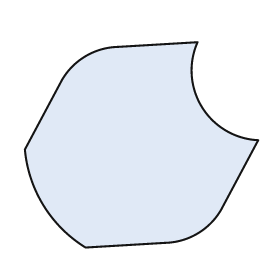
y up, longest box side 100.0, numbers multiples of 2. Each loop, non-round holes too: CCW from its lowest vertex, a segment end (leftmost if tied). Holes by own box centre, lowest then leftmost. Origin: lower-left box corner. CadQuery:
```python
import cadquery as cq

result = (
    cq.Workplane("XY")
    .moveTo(26.0, 0.0)
    .lineTo(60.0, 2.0)
    .threePointArc((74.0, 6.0), (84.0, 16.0))
    .lineTo(100.0, 46.0)
    .threePointArc((76.0, 60.0), (74.0, 88.0))
    .lineTo(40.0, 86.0)
    .threePointArc((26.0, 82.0), (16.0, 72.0))
    .lineTo(0.0, 42.0)
    .threePointArc((8.0, 18.0), (26.0, 0.0))
    .close()
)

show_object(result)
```